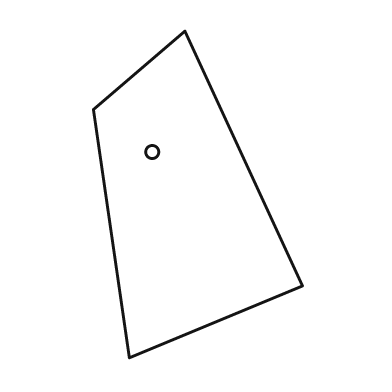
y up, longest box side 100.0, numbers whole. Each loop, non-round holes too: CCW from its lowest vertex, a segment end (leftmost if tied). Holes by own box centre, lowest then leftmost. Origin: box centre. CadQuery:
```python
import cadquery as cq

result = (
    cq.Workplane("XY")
    .moveTo(-21.0, -50.0)
    .lineTo(32.0, -28.0)
    .lineTo(-4.0, 50.0)
    .lineTo(-32.0, 26.0)
    .close()
    .moveTo(-14.0, 13.0)
    .circle(2.0)
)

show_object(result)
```